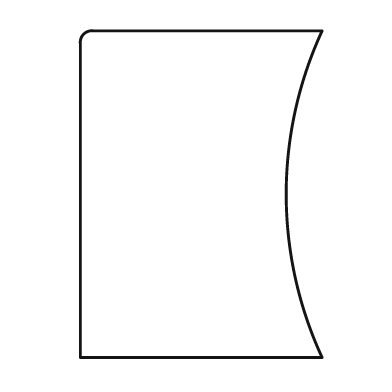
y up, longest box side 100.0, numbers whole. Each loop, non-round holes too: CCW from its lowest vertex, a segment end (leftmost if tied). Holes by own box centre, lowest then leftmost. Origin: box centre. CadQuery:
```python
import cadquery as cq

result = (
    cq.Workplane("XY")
    .moveTo(-37.0, -50.0)
    .lineTo(37.0, -50.0)
    .threePointArc((26.0, 0.0), (37.0, 50.0))
    .lineTo(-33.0, 50.0)
    .threePointArc((-36.0, 49.0), (-37.0, 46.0))
    .close()
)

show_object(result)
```